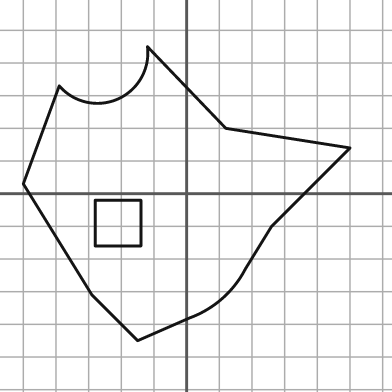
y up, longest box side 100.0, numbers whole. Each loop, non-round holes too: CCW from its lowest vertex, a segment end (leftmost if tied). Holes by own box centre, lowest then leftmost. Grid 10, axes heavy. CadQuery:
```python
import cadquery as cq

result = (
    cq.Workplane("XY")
    .moveTo(-15.0, -45.0)
    .lineTo(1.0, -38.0)
    .threePointArc((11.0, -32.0), (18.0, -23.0))
    .lineTo(26.0, -10.0)
    .lineTo(50.0, 14.0)
    .lineTo(12.0, 20.0)
    .lineTo(-12.0, 45.0)
    .threePointArc((-21.0, 29.0), (-39.0, 33.0))
    .lineTo(-50.0, 3.0)
    .lineTo(-29.0, -31.0)
    .close()
    .moveTo(-28.0, -16.0)
    .lineTo(-14.0, -16.0)
    .lineTo(-14.0, -2.0)
    .lineTo(-28.0, -2.0)
    .close()
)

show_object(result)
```